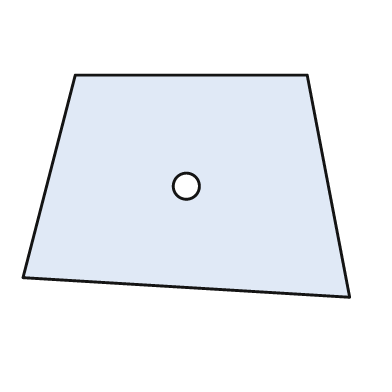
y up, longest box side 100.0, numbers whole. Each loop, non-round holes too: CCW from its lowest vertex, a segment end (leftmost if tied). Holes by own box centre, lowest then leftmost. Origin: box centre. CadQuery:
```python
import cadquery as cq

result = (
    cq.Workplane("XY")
    .moveTo(50.0, -34.0)
    .lineTo(37.0, 34.0)
    .lineTo(-34.0, 34.0)
    .lineTo(-50.0, -28.0)
    .close()
    .moveTo(0.0, 0.0)
    .circle(4.0)
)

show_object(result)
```